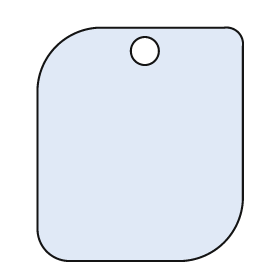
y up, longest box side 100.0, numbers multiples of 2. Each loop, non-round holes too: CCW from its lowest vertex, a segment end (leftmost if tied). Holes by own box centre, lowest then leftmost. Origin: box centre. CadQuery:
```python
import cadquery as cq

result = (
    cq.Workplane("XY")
    .moveTo(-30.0, -50.0)
    .lineTo(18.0, -50.0)
    .threePointArc((36.0, -42.0), (44.0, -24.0))
    .lineTo(44.0, 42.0)
    .threePointArc((42.0, 48.0), (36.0, 50.0))
    .lineTo(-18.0, 50.0)
    .threePointArc((-36.0, 42.0), (-44.0, 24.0))
    .lineTo(-44.0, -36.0)
    .threePointArc((-40.0, -46.0), (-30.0, -50.0))
    .close()
    .moveTo(2.0, 40.0)
    .circle(6.0)
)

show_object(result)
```